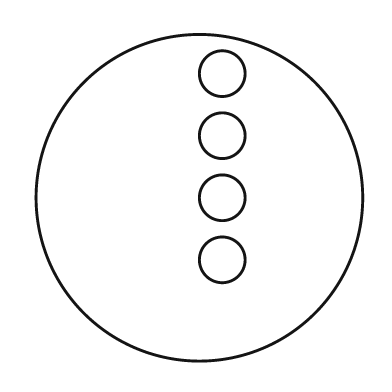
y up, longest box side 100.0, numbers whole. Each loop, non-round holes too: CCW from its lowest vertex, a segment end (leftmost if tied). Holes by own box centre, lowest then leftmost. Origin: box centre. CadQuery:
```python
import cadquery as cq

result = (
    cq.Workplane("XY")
    .moveTo(0.0, 0.0)
    .circle(50.0)
    .moveTo(7.0, -19.0)
    .circle(7.0)
    .moveTo(7.0, 0.0)
    .circle(7.0)
    .moveTo(7.0, 19.0)
    .circle(7.0)
    .moveTo(7.0, 38.0)
    .circle(7.0)
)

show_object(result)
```